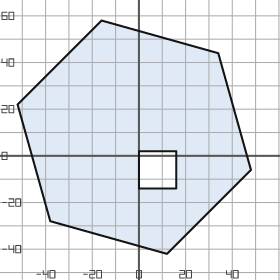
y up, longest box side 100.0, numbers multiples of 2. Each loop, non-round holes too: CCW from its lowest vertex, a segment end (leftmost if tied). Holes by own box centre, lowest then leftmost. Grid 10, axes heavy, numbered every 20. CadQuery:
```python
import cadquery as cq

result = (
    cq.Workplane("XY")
    .moveTo(12.0, -42.0)
    .lineTo(48.0, -6.0)
    .lineTo(34.0, 44.0)
    .lineTo(-16.0, 58.0)
    .lineTo(-52.0, 22.0)
    .lineTo(-38.0, -28.0)
    .close()
    .moveTo(0.0, -14.0)
    .lineTo(16.0, -14.0)
    .lineTo(16.0, 2.0)
    .lineTo(0.0, 2.0)
    .close()
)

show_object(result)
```